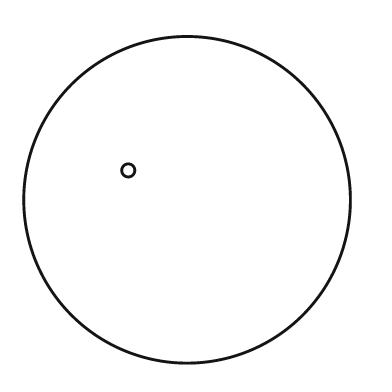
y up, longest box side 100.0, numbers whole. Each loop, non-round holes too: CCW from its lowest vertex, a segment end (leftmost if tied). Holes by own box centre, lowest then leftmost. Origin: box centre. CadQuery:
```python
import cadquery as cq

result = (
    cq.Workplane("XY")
    .moveTo(0.0, 0.0)
    .circle(50.0)
    .moveTo(-18.0, 9.0)
    .circle(2.0)
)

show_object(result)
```